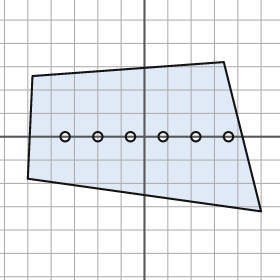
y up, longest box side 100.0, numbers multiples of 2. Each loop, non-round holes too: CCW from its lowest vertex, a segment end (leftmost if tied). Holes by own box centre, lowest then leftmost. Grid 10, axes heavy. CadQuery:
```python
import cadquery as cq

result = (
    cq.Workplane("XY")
    .moveTo(50.0, -32.0)
    .lineTo(34.0, 32.0)
    .lineTo(-48.0, 26.0)
    .lineTo(-50.0, -18.0)
    .close()
    .moveTo(-34.0, 0.0)
    .circle(2.0)
    .moveTo(-20.0, 0.0)
    .circle(2.0)
    .moveTo(-6.0, 0.0)
    .circle(2.0)
    .moveTo(8.0, 0.0)
    .circle(2.0)
    .moveTo(22.0, 0.0)
    .circle(2.0)
    .moveTo(36.0, 0.0)
    .circle(2.0)
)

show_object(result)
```